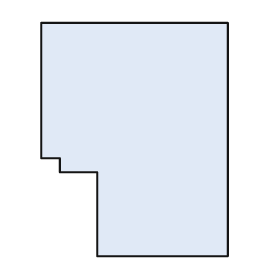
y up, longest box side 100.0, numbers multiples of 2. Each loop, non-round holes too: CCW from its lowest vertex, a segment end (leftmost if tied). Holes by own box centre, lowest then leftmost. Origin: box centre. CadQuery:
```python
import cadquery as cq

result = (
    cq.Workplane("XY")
    .moveTo(-16.0, -50.0)
    .lineTo(40.0, -50.0)
    .lineTo(40.0, 50.0)
    .lineTo(-40.0, 50.0)
    .lineTo(-40.0, -8.0)
    .lineTo(-32.0, -8.0)
    .lineTo(-32.0, -14.0)
    .lineTo(-16.0, -14.0)
    .close()
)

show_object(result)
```